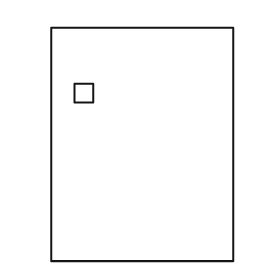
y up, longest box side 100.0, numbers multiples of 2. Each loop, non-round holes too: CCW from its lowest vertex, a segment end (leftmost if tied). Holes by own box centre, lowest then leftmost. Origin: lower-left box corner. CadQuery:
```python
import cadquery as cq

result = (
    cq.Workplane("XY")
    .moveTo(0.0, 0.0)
    .lineTo(78.0, 0.0)
    .lineTo(78.0, 100.0)
    .lineTo(0.0, 100.0)
    .close()
    .moveTo(10.0, 68.0)
    .lineTo(18.0, 68.0)
    .lineTo(18.0, 76.0)
    .lineTo(10.0, 76.0)
    .close()
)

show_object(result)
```